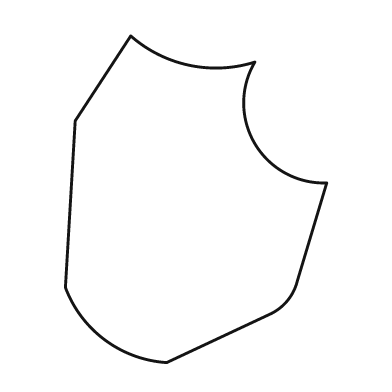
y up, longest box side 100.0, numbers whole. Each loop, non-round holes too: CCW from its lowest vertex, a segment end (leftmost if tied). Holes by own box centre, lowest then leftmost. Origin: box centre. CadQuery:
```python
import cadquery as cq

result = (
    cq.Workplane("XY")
    .moveTo(-9.0, -50.0)
    .lineTo(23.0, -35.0)
    .threePointArc((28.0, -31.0), (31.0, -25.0))
    .lineTo(40.0, 5.0)
    .threePointArc((18.0, 17.0), (18.0, 42.0))
    .threePointArc((-2.0, 41.0), (-20.0, 50.0))
    .lineTo(-37.0, 24.0)
    .lineTo(-40.0, -27.0)
    .threePointArc((-28.0, -43.0), (-9.0, -50.0))
    .close()
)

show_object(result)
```